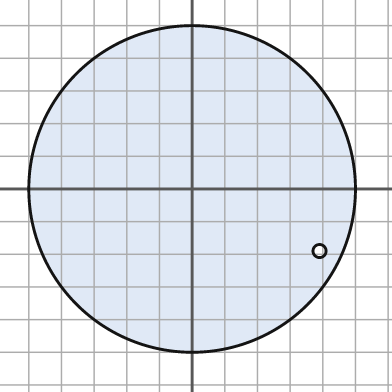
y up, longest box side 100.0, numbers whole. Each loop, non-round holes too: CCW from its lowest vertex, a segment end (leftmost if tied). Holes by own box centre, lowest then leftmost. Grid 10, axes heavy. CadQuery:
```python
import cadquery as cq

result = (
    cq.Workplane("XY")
    .moveTo(0.0, 0.0)
    .circle(50.0)
    .moveTo(39.0, -19.0)
    .circle(2.0)
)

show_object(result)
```